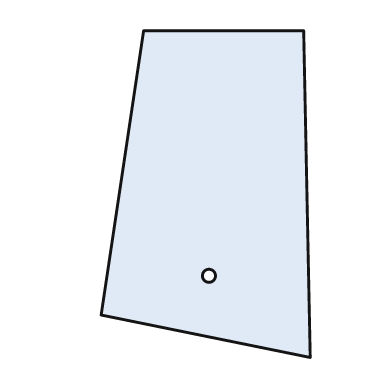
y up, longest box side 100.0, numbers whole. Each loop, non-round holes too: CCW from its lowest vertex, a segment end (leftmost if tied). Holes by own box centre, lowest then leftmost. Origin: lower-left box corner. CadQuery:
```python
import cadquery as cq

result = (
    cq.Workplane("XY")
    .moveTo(64.0, 0.0)
    .lineTo(62.0, 100.0)
    .lineTo(13.0, 100.0)
    .lineTo(0.0, 13.0)
    .close()
    .moveTo(33.0, 25.0)
    .circle(2.0)
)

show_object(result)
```